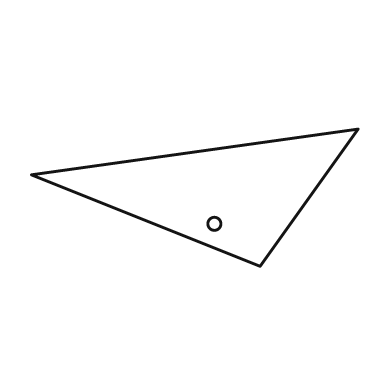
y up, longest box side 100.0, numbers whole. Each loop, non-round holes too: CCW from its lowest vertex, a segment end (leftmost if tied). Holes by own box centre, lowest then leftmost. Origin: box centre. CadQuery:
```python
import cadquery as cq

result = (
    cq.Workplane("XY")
    .moveTo(20.0, -21.0)
    .lineTo(50.0, 21.0)
    .lineTo(-50.0, 7.0)
    .close()
    .moveTo(6.0, -8.0)
    .circle(2.0)
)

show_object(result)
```